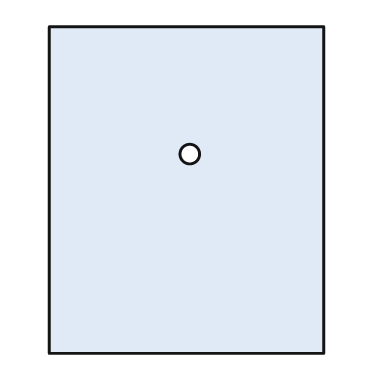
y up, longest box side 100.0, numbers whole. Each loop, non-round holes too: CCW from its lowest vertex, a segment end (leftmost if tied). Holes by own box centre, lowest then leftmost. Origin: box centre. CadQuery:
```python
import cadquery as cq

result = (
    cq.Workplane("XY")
    .moveTo(-42.0, -50.0)
    .lineTo(42.0, -50.0)
    .lineTo(42.0, 50.0)
    .lineTo(-42.0, 50.0)
    .close()
    .moveTo(1.0, 11.0)
    .circle(3.0)
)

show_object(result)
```